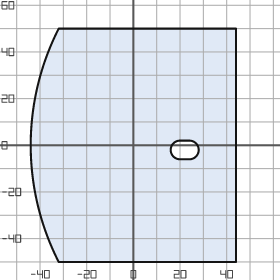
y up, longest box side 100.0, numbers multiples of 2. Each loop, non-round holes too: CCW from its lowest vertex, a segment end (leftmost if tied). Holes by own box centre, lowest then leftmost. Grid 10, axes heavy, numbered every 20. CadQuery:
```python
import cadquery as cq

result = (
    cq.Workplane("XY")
    .moveTo(-32.0, -50.0)
    .lineTo(44.0, -50.0)
    .lineTo(44.0, 50.0)
    .lineTo(-32.0, 50.0)
    .threePointArc((-44.0, 0.0), (-32.0, -50.0))
    .close()
    .moveTo(20.0, -6.0)
    .lineTo(24.0, -6.0)
    .threePointArc((28.0, -2.0), (24.0, 2.0))
    .lineTo(20.0, 2.0)
    .threePointArc((16.0, -2.0), (20.0, -6.0))
    .close()
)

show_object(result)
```